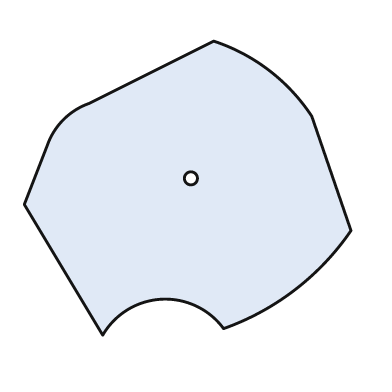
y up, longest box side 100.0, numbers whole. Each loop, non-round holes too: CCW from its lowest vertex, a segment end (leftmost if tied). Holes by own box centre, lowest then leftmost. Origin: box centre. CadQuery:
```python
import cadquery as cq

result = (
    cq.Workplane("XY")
    .moveTo(-26.0, -45.0)
    .threePointArc((-8.0, -34.0), (11.0, -43.0))
    .threePointArc((33.0, -31.0), (50.0, -13.0))
    .lineTo(38.0, 22.0)
    .threePointArc((25.0, 36.0), (8.0, 45.0))
    .lineTo(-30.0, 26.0)
    .threePointArc((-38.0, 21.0), (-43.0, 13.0))
    .lineTo(-50.0, -5.0)
    .close()
    .moveTo(1.0, 3.0)
    .circle(2.0)
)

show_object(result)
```